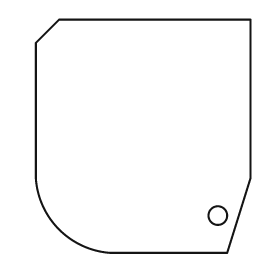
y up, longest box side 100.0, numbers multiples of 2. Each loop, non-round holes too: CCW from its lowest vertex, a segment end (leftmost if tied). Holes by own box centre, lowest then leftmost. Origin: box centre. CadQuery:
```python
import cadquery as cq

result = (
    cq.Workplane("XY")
    .moveTo(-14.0, -50.0)
    .lineTo(36.0, -50.0)
    .lineTo(46.0, -18.0)
    .lineTo(46.0, 50.0)
    .lineTo(-36.0, 50.0)
    .lineTo(-46.0, 40.0)
    .lineTo(-46.0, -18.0)
    .threePointArc((-36.0, -40.0), (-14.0, -50.0))
    .close()
    .moveTo(32.0, -34.0)
    .circle(4.0)
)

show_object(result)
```